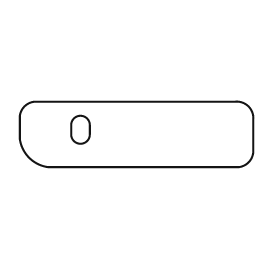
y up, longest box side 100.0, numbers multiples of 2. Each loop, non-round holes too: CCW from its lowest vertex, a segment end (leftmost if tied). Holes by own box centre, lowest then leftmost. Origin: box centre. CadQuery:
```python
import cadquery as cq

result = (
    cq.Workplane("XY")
    .moveTo(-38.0, -14.0)
    .lineTo(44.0, -14.0)
    .threePointArc((48.0, -12.0), (50.0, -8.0))
    .lineTo(50.0, 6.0)
    .threePointArc((48.0, 12.0), (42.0, 14.0))
    .lineTo(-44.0, 14.0)
    .threePointArc((-48.0, 12.0), (-50.0, 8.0))
    .lineTo(-50.0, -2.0)
    .threePointArc((-46.0, -10.0), (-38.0, -14.0))
    .close()
    .moveTo(-28.0, 0.0)
    .threePointArc((-24.0, -4.0), (-20.0, 0.0))
    .lineTo(-20.0, 4.0)
    .threePointArc((-24.0, 8.0), (-28.0, 4.0))
    .close()
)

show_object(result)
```